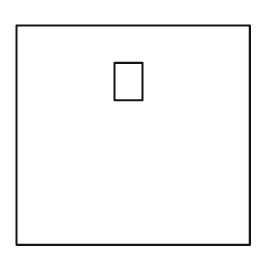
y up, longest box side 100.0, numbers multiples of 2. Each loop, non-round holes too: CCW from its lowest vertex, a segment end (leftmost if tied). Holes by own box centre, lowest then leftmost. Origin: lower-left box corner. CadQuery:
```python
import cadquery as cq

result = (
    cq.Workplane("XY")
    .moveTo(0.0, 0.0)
    .lineTo(100.0, 0.0)
    .lineTo(100.0, 94.0)
    .lineTo(0.0, 94.0)
    .close()
    .moveTo(42.0, 62.0)
    .lineTo(54.0, 62.0)
    .lineTo(54.0, 78.0)
    .lineTo(42.0, 78.0)
    .close()
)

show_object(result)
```